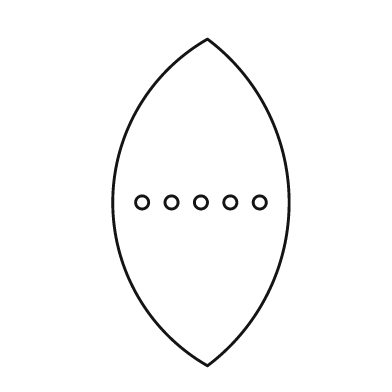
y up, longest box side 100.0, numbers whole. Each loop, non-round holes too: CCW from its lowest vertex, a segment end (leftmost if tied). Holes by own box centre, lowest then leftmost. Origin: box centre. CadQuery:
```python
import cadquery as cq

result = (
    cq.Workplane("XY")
    .moveTo(2.0, -50.0)
    .threePointArc((27.0, 0.0), (2.0, 50.0))
    .threePointArc((-27.0, 0.0), (2.0, -50.0))
    .close()
    .moveTo(-18.0, 0.0)
    .circle(2.0)
    .moveTo(-9.0, 0.0)
    .circle(2.0)
    .moveTo(0.0, 0.0)
    .circle(2.0)
    .moveTo(9.0, 0.0)
    .circle(2.0)
    .moveTo(18.0, 0.0)
    .circle(2.0)
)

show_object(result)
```